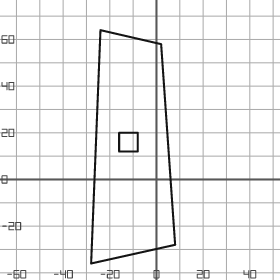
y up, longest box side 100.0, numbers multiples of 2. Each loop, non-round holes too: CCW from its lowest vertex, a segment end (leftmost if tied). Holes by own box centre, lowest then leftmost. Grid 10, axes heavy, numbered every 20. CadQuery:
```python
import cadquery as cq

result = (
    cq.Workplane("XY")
    .moveTo(-28.0, -36.0)
    .lineTo(8.0, -28.0)
    .lineTo(2.0, 58.0)
    .lineTo(-24.0, 64.0)
    .close()
    .moveTo(-16.0, 12.0)
    .lineTo(-8.0, 12.0)
    .lineTo(-8.0, 20.0)
    .lineTo(-16.0, 20.0)
    .close()
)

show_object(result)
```